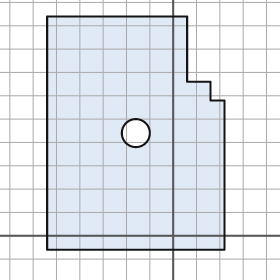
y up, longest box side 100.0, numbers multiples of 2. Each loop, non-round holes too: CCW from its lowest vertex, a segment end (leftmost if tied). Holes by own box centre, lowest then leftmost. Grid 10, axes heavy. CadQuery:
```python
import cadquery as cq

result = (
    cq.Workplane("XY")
    .moveTo(-54.0, -6.0)
    .lineTo(22.0, -6.0)
    .lineTo(22.0, 58.0)
    .lineTo(16.0, 58.0)
    .lineTo(16.0, 66.0)
    .lineTo(6.0, 66.0)
    .lineTo(6.0, 94.0)
    .lineTo(-54.0, 94.0)
    .close()
    .moveTo(-16.0, 44.0)
    .circle(6.0)
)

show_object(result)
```